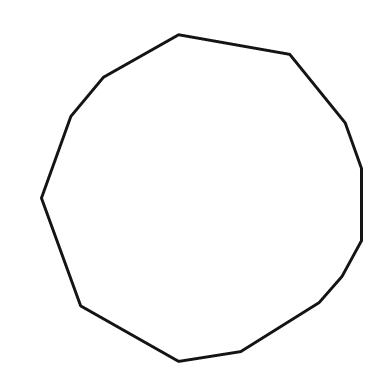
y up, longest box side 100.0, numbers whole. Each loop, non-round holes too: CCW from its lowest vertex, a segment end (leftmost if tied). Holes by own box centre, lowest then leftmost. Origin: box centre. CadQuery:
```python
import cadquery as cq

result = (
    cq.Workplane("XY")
    .moveTo(-7.0, -50.0)
    .lineTo(12.0, -47.0)
    .lineTo(36.0, -32.0)
    .lineTo(43.0, -24.0)
    .lineTo(49.0, -13.0)
    .lineTo(49.0, 9.0)
    .lineTo(44.0, 23.0)
    .lineTo(27.0, 44.0)
    .lineTo(-7.0, 50.0)
    .lineTo(-30.0, 37.0)
    .lineTo(-40.0, 25.0)
    .lineTo(-49.0, 0.0)
    .lineTo(-37.0, -33.0)
    .close()
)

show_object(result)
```